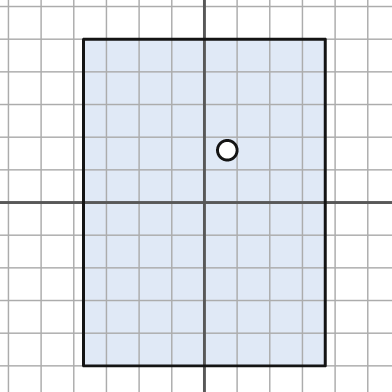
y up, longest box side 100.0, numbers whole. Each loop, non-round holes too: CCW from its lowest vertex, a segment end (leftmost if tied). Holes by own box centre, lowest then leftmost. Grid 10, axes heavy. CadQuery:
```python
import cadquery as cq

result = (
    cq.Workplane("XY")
    .moveTo(-37.0, -50.0)
    .lineTo(37.0, -50.0)
    .lineTo(37.0, 50.0)
    .lineTo(-37.0, 50.0)
    .close()
    .moveTo(7.0, 16.0)
    .circle(3.0)
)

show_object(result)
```